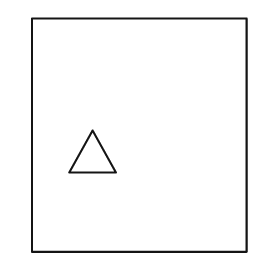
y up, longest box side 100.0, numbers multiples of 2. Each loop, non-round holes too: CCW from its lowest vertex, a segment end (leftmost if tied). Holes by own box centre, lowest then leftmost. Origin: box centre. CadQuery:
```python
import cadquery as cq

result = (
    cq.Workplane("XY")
    .moveTo(-46.0, -50.0)
    .lineTo(46.0, -50.0)
    .lineTo(46.0, 50.0)
    .lineTo(-46.0, 50.0)
    .close()
    .moveTo(-30.0, -16.0)
    .lineTo(-10.0, -16.0)
    .lineTo(-20.0, 2.0)
    .close()
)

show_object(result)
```